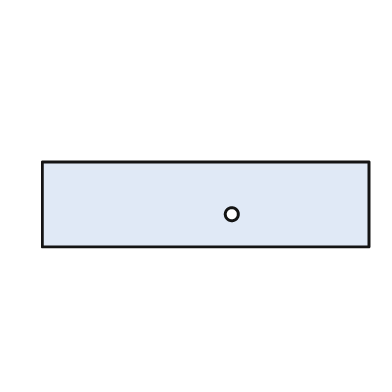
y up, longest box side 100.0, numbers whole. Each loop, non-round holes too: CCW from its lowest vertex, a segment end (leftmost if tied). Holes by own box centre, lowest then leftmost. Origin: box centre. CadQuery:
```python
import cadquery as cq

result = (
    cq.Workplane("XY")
    .moveTo(-50.0, -13.0)
    .lineTo(50.0, -13.0)
    .lineTo(50.0, 13.0)
    .lineTo(-50.0, 13.0)
    .close()
    .moveTo(8.0, -3.0)
    .circle(2.0)
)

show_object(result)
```